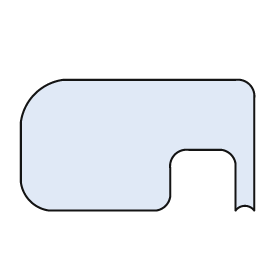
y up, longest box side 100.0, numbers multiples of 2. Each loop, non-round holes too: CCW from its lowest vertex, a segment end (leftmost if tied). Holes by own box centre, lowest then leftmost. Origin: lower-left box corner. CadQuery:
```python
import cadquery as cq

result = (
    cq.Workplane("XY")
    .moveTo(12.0, 0.0)
    .lineTo(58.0, 0.0)
    .threePointArc((62.0, 2.0), (64.0, 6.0))
    .lineTo(64.0, 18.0)
    .threePointArc((66.0, 24.0), (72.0, 26.0))
    .lineTo(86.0, 26.0)
    .threePointArc((90.0, 24.0), (92.0, 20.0))
    .lineTo(92.0, 0.0)
    .threePointArc((96.0, 2.0), (100.0, 0.0))
    .lineTo(100.0, 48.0)
    .threePointArc((98.0, 54.0), (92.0, 56.0))
    .lineTo(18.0, 56.0)
    .threePointArc((6.0, 50.0), (0.0, 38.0))
    .lineTo(0.0, 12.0)
    .threePointArc((4.0, 4.0), (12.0, 0.0))
    .close()
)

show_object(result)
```